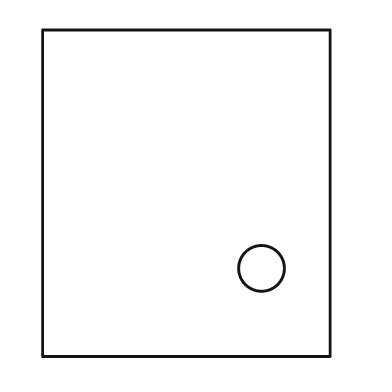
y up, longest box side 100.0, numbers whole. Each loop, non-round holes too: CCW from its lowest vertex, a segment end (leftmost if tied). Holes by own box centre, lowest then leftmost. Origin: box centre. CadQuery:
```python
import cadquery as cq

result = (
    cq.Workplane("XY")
    .moveTo(-44.0, -50.0)
    .lineTo(44.0, -50.0)
    .lineTo(44.0, 50.0)
    .lineTo(-44.0, 50.0)
    .close()
    .moveTo(23.0, -23.0)
    .circle(7.0)
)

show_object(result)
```